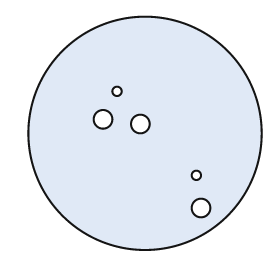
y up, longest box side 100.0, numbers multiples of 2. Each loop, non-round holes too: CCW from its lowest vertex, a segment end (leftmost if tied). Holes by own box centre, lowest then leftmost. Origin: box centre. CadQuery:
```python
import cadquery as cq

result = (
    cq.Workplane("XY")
    .moveTo(0.0, 0.0)
    .circle(50.0)
    .moveTo(24.0, -32.0)
    .circle(4.0)
    .moveTo(22.0, -18.0)
    .circle(2.0)
    .moveTo(-2.0, 4.0)
    .circle(4.0)
    .moveTo(-18.0, 6.0)
    .circle(4.0)
    .moveTo(-12.0, 18.0)
    .circle(2.0)
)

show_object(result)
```